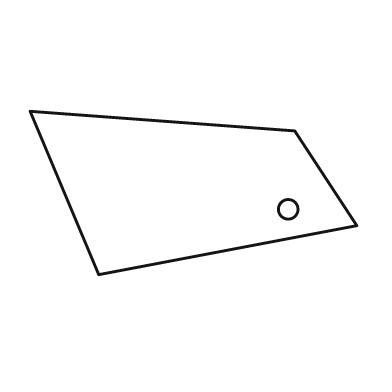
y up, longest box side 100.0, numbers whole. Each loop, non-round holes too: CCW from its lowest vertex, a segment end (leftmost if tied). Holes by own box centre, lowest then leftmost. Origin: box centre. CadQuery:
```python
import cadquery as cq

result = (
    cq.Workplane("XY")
    .moveTo(-29.0, -25.0)
    .lineTo(50.0, -10.0)
    .lineTo(31.0, 19.0)
    .lineTo(-50.0, 25.0)
    .close()
    .moveTo(29.0, -5.0)
    .circle(3.0)
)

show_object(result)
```